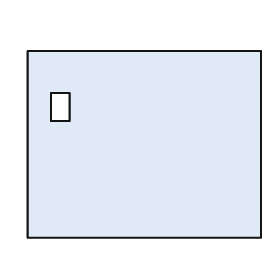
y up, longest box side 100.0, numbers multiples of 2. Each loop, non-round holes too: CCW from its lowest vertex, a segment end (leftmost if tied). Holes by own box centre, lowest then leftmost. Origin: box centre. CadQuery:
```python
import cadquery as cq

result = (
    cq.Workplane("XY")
    .moveTo(-50.0, -40.0)
    .lineTo(50.0, -40.0)
    .lineTo(50.0, 40.0)
    .lineTo(-50.0, 40.0)
    .close()
    .moveTo(-40.0, 10.0)
    .lineTo(-32.0, 10.0)
    .lineTo(-32.0, 22.0)
    .lineTo(-40.0, 22.0)
    .close()
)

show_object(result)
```